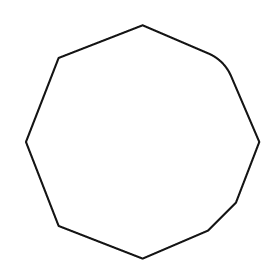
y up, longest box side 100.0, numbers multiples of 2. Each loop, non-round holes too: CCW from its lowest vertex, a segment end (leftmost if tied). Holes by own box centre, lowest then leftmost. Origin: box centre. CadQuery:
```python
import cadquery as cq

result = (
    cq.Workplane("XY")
    .moveTo(0.0, -50.0)
    .lineTo(28.0, -38.0)
    .lineTo(40.0, -26.0)
    .lineTo(50.0, 0.0)
    .lineTo(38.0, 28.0)
    .threePointArc((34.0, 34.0), (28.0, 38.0))
    .lineTo(0.0, 50.0)
    .lineTo(-36.0, 36.0)
    .lineTo(-50.0, 0.0)
    .lineTo(-36.0, -36.0)
    .close()
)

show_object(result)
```